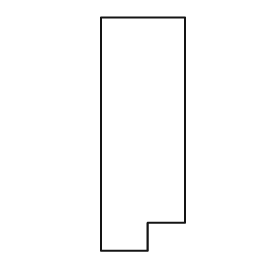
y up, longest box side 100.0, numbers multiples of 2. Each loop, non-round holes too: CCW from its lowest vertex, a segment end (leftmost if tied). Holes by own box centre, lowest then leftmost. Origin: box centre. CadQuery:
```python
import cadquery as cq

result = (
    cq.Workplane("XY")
    .moveTo(-18.0, -50.0)
    .lineTo(2.0, -50.0)
    .lineTo(2.0, -38.0)
    .lineTo(18.0, -38.0)
    .lineTo(18.0, 50.0)
    .lineTo(-18.0, 50.0)
    .close()
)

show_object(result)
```